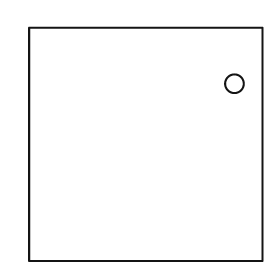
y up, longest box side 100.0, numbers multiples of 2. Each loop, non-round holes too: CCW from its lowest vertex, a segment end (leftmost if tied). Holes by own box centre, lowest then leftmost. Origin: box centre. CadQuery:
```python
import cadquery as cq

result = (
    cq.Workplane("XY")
    .moveTo(-50.0, -50.0)
    .lineTo(50.0, -50.0)
    .lineTo(50.0, 50.0)
    .lineTo(-50.0, 50.0)
    .close()
    .moveTo(38.0, 26.0)
    .circle(4.0)
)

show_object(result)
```